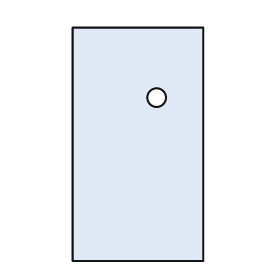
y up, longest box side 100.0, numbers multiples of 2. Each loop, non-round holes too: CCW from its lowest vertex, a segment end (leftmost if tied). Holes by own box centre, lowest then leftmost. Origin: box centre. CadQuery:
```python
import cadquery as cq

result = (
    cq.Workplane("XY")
    .moveTo(-28.0, -50.0)
    .lineTo(28.0, -50.0)
    .lineTo(28.0, 50.0)
    .lineTo(-28.0, 50.0)
    .close()
    .moveTo(8.0, 20.0)
    .circle(4.0)
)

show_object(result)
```